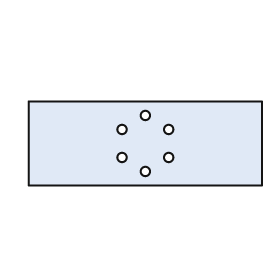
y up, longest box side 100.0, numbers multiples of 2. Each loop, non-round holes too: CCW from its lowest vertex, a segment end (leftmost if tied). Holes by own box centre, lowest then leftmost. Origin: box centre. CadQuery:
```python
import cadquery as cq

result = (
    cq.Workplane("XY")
    .moveTo(-50.0, -18.0)
    .lineTo(50.0, -18.0)
    .lineTo(50.0, 18.0)
    .lineTo(-50.0, 18.0)
    .close()
    .moveTo(0.0, -12.0)
    .circle(2.0)
    .moveTo(-10.0, -6.0)
    .circle(2.0)
    .moveTo(10.0, -6.0)
    .circle(2.0)
    .moveTo(-10.0, 6.0)
    .circle(2.0)
    .moveTo(10.0, 6.0)
    .circle(2.0)
    .moveTo(0.0, 12.0)
    .circle(2.0)
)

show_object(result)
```